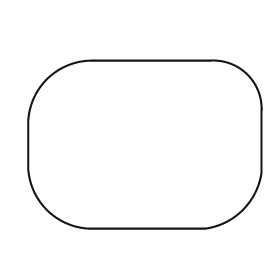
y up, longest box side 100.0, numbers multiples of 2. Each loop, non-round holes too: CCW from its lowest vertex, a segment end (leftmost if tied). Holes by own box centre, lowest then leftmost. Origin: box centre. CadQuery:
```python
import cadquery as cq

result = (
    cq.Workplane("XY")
    .moveTo(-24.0, -36.0)
    .lineTo(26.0, -36.0)
    .threePointArc((42.0, -28.0), (50.0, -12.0))
    .lineTo(50.0, 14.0)
    .threePointArc((44.0, 30.0), (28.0, 36.0))
    .lineTo(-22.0, 36.0)
    .threePointArc((-42.0, 28.0), (-50.0, 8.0))
    .lineTo(-50.0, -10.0)
    .threePointArc((-42.0, -28.0), (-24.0, -36.0))
    .close()
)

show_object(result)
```